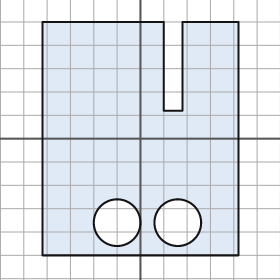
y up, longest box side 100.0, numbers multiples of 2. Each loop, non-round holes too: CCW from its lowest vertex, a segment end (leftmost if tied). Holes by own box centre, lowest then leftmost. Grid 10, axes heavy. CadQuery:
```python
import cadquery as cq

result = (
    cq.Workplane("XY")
    .moveTo(-42.0, -50.0)
    .lineTo(42.0, -50.0)
    .lineTo(42.0, 50.0)
    .lineTo(18.0, 50.0)
    .lineTo(18.0, 12.0)
    .lineTo(10.0, 12.0)
    .lineTo(10.0, 50.0)
    .lineTo(-42.0, 50.0)
    .close()
    .moveTo(-10.0, -36.0)
    .circle(10.0)
    .moveTo(16.0, -36.0)
    .circle(10.0)
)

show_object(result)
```